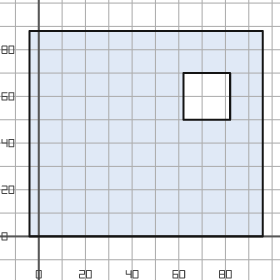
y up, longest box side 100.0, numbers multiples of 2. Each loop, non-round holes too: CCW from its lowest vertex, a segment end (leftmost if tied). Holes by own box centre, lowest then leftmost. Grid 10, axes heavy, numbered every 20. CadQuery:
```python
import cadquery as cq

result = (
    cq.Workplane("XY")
    .moveTo(-4.0, 0.0)
    .lineTo(96.0, 0.0)
    .lineTo(96.0, 88.0)
    .lineTo(-4.0, 88.0)
    .close()
    .moveTo(62.0, 50.0)
    .lineTo(82.0, 50.0)
    .lineTo(82.0, 70.0)
    .lineTo(62.0, 70.0)
    .close()
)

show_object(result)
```